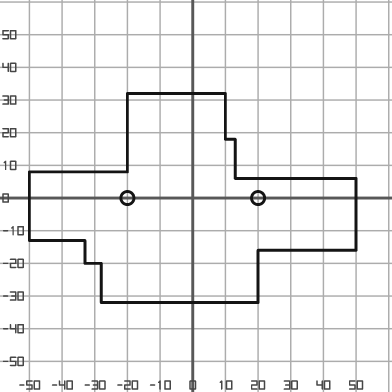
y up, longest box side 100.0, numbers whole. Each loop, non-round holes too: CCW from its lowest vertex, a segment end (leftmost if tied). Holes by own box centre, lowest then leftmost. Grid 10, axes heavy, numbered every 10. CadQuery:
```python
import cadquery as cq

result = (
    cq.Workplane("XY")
    .moveTo(-28.0, -32.0)
    .lineTo(20.0, -32.0)
    .lineTo(20.0, -16.0)
    .lineTo(50.0, -16.0)
    .lineTo(50.0, 6.0)
    .lineTo(13.0, 6.0)
    .lineTo(13.0, 18.0)
    .lineTo(10.0, 18.0)
    .lineTo(10.0, 32.0)
    .lineTo(-20.0, 32.0)
    .lineTo(-20.0, 8.0)
    .lineTo(-50.0, 8.0)
    .lineTo(-50.0, -13.0)
    .lineTo(-33.0, -13.0)
    .lineTo(-33.0, -20.0)
    .lineTo(-28.0, -20.0)
    .close()
    .moveTo(-20.0, 0.0)
    .circle(2.0)
    .moveTo(20.0, 0.0)
    .circle(2.0)
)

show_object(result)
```